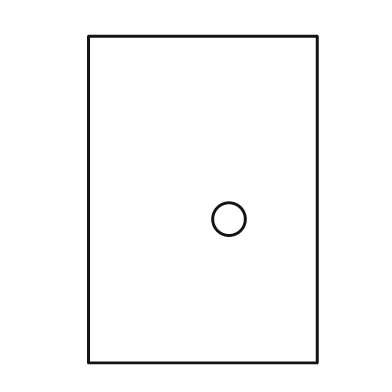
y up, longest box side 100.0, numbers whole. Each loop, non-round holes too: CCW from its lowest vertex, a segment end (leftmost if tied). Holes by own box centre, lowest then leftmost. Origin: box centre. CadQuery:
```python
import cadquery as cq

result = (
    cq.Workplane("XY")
    .moveTo(-35.0, -50.0)
    .lineTo(35.0, -50.0)
    .lineTo(35.0, 50.0)
    .lineTo(-35.0, 50.0)
    .close()
    .moveTo(8.0, -6.0)
    .circle(5.0)
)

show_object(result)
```